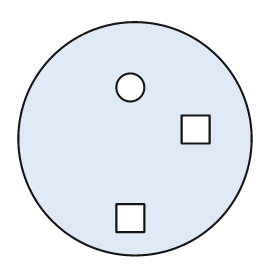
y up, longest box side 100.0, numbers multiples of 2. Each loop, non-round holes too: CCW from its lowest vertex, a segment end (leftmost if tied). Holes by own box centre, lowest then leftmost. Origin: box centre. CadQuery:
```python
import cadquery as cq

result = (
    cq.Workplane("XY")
    .moveTo(0.0, 0.0)
    .circle(50.0)
    .moveTo(-8.0, -40.0)
    .lineTo(4.0, -40.0)
    .lineTo(4.0, -28.0)
    .lineTo(-8.0, -28.0)
    .close()
    .moveTo(20.0, -2.0)
    .lineTo(32.0, -2.0)
    .lineTo(32.0, 10.0)
    .lineTo(20.0, 10.0)
    .close()
    .moveTo(-2.0, 22.0)
    .circle(6.0)
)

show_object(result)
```